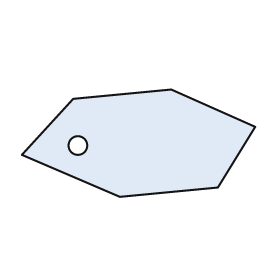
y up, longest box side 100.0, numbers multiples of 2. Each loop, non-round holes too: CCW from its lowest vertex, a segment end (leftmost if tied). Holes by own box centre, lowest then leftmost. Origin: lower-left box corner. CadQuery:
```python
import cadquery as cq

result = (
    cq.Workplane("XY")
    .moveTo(42.0, 0.0)
    .lineTo(84.0, 4.0)
    .lineTo(100.0, 30.0)
    .lineTo(64.0, 46.0)
    .lineTo(22.0, 42.0)
    .lineTo(0.0, 18.0)
    .close()
    .moveTo(24.0, 22.0)
    .circle(4.0)
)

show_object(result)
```